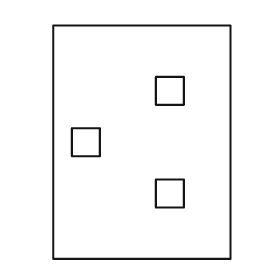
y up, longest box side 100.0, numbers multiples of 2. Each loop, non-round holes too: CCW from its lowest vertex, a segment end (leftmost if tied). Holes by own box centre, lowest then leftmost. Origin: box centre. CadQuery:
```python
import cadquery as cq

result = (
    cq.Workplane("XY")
    .moveTo(-38.0, -50.0)
    .lineTo(38.0, -50.0)
    .lineTo(38.0, 50.0)
    .lineTo(-38.0, 50.0)
    .close()
    .moveTo(6.0, -28.0)
    .lineTo(18.0, -28.0)
    .lineTo(18.0, -16.0)
    .lineTo(6.0, -16.0)
    .close()
    .moveTo(-30.0, -6.0)
    .lineTo(-18.0, -6.0)
    .lineTo(-18.0, 6.0)
    .lineTo(-30.0, 6.0)
    .close()
    .moveTo(6.0, 16.0)
    .lineTo(18.0, 16.0)
    .lineTo(18.0, 28.0)
    .lineTo(6.0, 28.0)
    .close()
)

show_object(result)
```